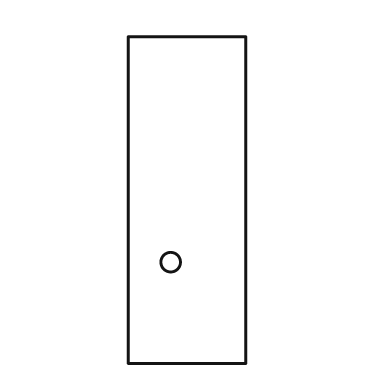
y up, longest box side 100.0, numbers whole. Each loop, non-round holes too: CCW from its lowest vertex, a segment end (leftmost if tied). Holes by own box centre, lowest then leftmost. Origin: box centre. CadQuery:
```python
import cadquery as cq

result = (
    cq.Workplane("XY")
    .moveTo(-18.0, -50.0)
    .lineTo(18.0, -50.0)
    .lineTo(18.0, 50.0)
    .lineTo(-18.0, 50.0)
    .close()
    .moveTo(-5.0, -19.0)
    .circle(3.0)
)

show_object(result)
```